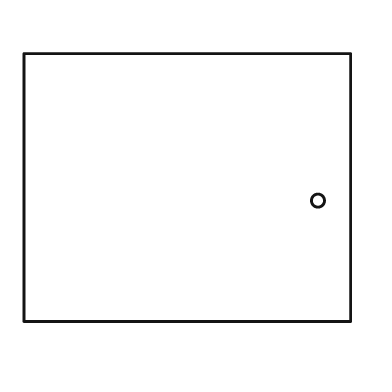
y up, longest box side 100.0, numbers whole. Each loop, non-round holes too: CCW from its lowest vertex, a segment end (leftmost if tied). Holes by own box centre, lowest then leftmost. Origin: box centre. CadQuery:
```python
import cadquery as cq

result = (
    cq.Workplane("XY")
    .moveTo(-50.0, -41.0)
    .lineTo(50.0, -41.0)
    .lineTo(50.0, 41.0)
    .lineTo(-50.0, 41.0)
    .close()
    .moveTo(40.0, -4.0)
    .circle(2.0)
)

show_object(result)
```